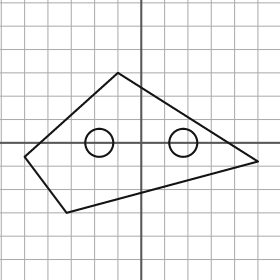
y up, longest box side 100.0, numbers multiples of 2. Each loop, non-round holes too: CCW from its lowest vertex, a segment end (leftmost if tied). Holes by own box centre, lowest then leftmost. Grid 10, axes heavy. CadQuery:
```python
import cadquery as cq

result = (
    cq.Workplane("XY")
    .moveTo(-32.0, -30.0)
    .lineTo(50.0, -8.0)
    .lineTo(-10.0, 30.0)
    .lineTo(-50.0, -6.0)
    .close()
    .moveTo(-18.0, 0.0)
    .circle(6.0)
    .moveTo(18.0, 0.0)
    .circle(6.0)
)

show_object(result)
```